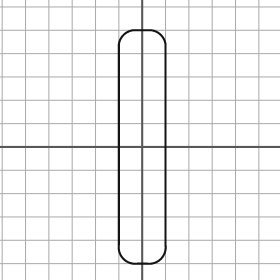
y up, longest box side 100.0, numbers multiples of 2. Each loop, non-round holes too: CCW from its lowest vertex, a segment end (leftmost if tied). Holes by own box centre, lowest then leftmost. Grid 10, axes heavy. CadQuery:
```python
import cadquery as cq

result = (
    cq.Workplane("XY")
    .moveTo(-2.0, -50.0)
    .lineTo(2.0, -50.0)
    .threePointArc((8.0, -48.0), (10.0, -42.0))
    .lineTo(10.0, 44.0)
    .threePointArc((8.0, 48.0), (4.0, 50.0))
    .lineTo(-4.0, 50.0)
    .threePointArc((-8.0, 48.0), (-10.0, 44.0))
    .lineTo(-10.0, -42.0)
    .threePointArc((-8.0, -48.0), (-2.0, -50.0))
    .close()
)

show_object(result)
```